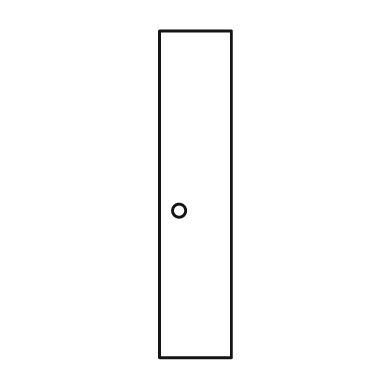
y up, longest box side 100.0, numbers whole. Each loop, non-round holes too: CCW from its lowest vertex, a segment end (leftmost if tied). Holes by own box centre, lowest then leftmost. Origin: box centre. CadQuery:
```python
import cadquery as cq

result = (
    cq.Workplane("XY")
    .moveTo(-11.0, -50.0)
    .lineTo(11.0, -50.0)
    .lineTo(11.0, 50.0)
    .lineTo(-11.0, 50.0)
    .close()
    .moveTo(-5.0, -5.0)
    .circle(2.0)
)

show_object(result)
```